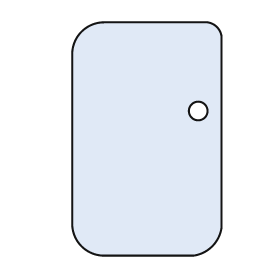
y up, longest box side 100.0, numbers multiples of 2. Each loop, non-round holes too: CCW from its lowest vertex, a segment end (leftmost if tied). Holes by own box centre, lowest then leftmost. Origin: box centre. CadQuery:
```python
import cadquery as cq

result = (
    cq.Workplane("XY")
    .moveTo(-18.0, -50.0)
    .lineTo(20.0, -50.0)
    .threePointArc((28.0, -46.0), (32.0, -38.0))
    .lineTo(32.0, 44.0)
    .threePointArc((30.0, 48.0), (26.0, 50.0))
    .lineTo(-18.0, 50.0)
    .threePointArc((-28.0, 46.0), (-32.0, 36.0))
    .lineTo(-32.0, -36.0)
    .threePointArc((-28.0, -46.0), (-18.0, -50.0))
    .close()
    .moveTo(22.0, 12.0)
    .circle(4.0)
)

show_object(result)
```